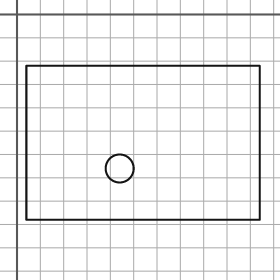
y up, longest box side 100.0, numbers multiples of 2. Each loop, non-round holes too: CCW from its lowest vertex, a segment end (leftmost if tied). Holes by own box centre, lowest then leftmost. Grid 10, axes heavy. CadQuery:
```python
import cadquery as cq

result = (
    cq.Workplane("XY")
    .moveTo(4.0, -88.0)
    .lineTo(104.0, -88.0)
    .lineTo(104.0, -22.0)
    .lineTo(4.0, -22.0)
    .close()
    .moveTo(44.0, -66.0)
    .circle(6.0)
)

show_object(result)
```